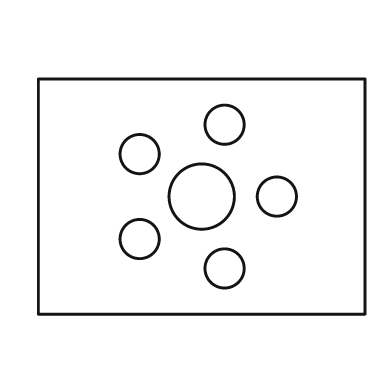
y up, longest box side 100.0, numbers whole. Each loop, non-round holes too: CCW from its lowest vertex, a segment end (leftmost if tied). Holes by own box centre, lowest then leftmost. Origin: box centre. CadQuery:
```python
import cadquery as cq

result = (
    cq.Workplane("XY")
    .moveTo(-50.0, -36.0)
    .lineTo(50.0, -36.0)
    .lineTo(50.0, 36.0)
    .lineTo(-50.0, 36.0)
    .close()
    .moveTo(7.0, -22.0)
    .circle(6.0)
    .moveTo(-19.0, -13.0)
    .circle(6.0)
    .moveTo(0.0, 0.0)
    .circle(10.0)
    .moveTo(23.0, 0.0)
    .circle(6.0)
    .moveTo(-19.0, 13.0)
    .circle(6.0)
    .moveTo(7.0, 22.0)
    .circle(6.0)
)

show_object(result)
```